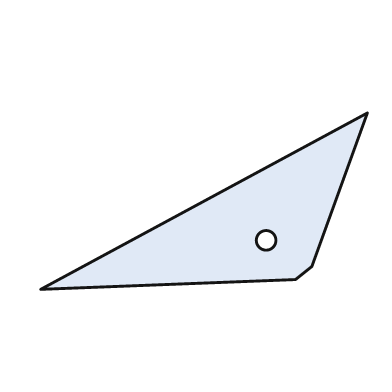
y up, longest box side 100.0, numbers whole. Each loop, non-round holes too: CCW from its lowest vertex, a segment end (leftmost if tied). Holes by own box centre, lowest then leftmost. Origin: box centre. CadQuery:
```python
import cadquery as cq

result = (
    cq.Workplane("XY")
    .moveTo(-50.0, -27.0)
    .lineTo(28.0, -24.0)
    .lineTo(33.0, -20.0)
    .lineTo(50.0, 27.0)
    .close()
    .moveTo(19.0, -12.0)
    .circle(3.0)
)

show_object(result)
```